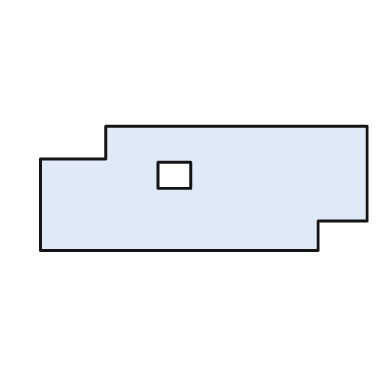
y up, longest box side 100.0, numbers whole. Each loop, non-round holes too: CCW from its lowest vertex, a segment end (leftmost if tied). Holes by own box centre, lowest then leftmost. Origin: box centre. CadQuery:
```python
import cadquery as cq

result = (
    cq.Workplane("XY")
    .moveTo(-50.0, -19.0)
    .lineTo(35.0, -19.0)
    .lineTo(35.0, -10.0)
    .lineTo(50.0, -10.0)
    .lineTo(50.0, 19.0)
    .lineTo(-30.0, 19.0)
    .lineTo(-30.0, 9.0)
    .lineTo(-50.0, 9.0)
    .close()
    .moveTo(-14.0, 0.0)
    .lineTo(-4.0, 0.0)
    .lineTo(-4.0, 8.0)
    .lineTo(-14.0, 8.0)
    .close()
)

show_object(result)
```